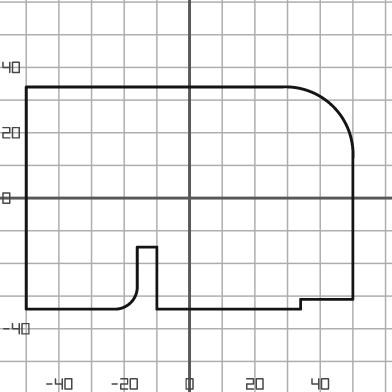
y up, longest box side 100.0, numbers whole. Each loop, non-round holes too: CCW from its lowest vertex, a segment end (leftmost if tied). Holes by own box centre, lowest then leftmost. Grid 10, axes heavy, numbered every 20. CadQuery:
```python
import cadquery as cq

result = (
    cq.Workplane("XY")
    .moveTo(-50.0, -34.0)
    .lineTo(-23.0, -34.0)
    .threePointArc((-18.0, -32.0), (-16.0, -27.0))
    .lineTo(-16.0, -15.0)
    .lineTo(-10.0, -15.0)
    .lineTo(-10.0, -34.0)
    .lineTo(34.0, -34.0)
    .lineTo(34.0, -31.0)
    .lineTo(50.0, -31.0)
    .lineTo(50.0, 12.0)
    .threePointArc((44.0, 28.0), (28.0, 34.0))
    .lineTo(-50.0, 34.0)
    .close()
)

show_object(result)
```